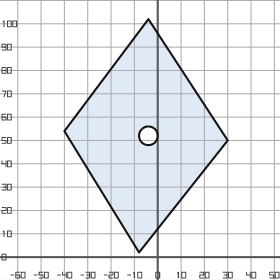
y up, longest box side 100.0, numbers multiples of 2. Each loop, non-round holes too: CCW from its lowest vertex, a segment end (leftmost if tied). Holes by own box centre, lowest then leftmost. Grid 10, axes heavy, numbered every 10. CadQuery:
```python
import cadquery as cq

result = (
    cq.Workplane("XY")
    .moveTo(-8.0, 2.0)
    .lineTo(30.0, 50.0)
    .lineTo(-4.0, 102.0)
    .lineTo(-40.0, 54.0)
    .close()
    .moveTo(-4.0, 52.0)
    .circle(4.0)
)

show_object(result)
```